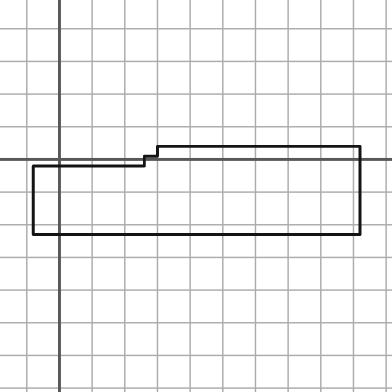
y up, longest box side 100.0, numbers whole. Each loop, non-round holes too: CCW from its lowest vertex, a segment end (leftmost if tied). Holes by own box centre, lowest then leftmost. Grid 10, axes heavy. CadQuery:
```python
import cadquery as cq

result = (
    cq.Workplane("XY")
    .moveTo(-8.0, -23.0)
    .lineTo(92.0, -23.0)
    .lineTo(92.0, 4.0)
    .lineTo(30.0, 4.0)
    .lineTo(30.0, 1.0)
    .lineTo(26.0, 1.0)
    .lineTo(26.0, -2.0)
    .lineTo(-8.0, -2.0)
    .close()
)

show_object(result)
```